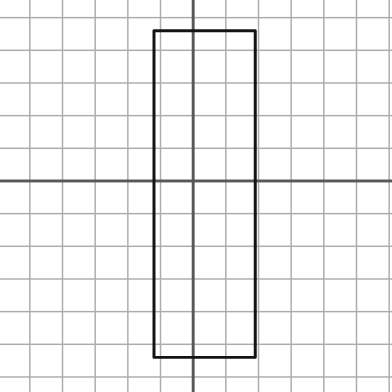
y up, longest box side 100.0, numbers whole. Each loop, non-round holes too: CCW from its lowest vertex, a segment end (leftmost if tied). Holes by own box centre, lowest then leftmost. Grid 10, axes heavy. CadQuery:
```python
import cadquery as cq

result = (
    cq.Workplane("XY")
    .moveTo(-12.0, -54.0)
    .lineTo(19.0, -54.0)
    .lineTo(19.0, 46.0)
    .lineTo(-12.0, 46.0)
    .close()
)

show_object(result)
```